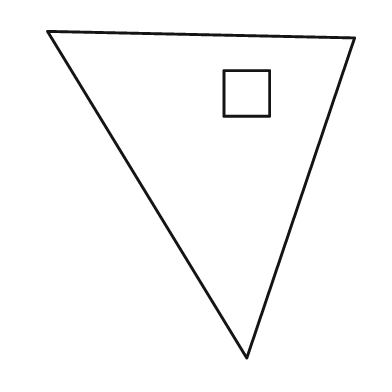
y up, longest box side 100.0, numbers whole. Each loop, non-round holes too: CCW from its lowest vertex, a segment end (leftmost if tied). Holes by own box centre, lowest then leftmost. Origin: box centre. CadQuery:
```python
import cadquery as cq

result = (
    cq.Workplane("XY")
    .moveTo(14.0, -50.0)
    .lineTo(47.0, 48.0)
    .lineTo(-47.0, 50.0)
    .close()
    .moveTo(7.0, 24.0)
    .lineTo(21.0, 24.0)
    .lineTo(21.0, 38.0)
    .lineTo(7.0, 38.0)
    .close()
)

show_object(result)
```